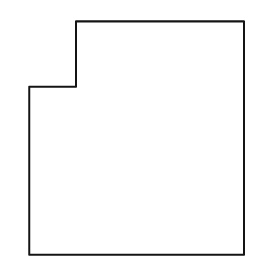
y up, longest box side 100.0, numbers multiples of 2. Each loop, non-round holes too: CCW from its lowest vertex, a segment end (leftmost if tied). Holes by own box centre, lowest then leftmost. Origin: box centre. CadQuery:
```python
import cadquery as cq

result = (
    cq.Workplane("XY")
    .moveTo(-46.0, -50.0)
    .lineTo(46.0, -50.0)
    .lineTo(46.0, 50.0)
    .lineTo(-26.0, 50.0)
    .lineTo(-26.0, 22.0)
    .lineTo(-46.0, 22.0)
    .close()
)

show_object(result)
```